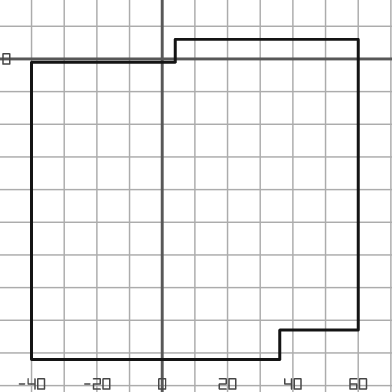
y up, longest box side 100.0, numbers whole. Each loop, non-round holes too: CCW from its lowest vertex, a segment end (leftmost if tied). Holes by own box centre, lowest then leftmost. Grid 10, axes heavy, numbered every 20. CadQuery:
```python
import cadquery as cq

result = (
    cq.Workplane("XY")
    .moveTo(-40.0, -92.0)
    .lineTo(36.0, -92.0)
    .lineTo(36.0, -83.0)
    .lineTo(60.0, -83.0)
    .lineTo(60.0, 6.0)
    .lineTo(4.0, 6.0)
    .lineTo(4.0, -1.0)
    .lineTo(-40.0, -1.0)
    .close()
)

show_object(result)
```